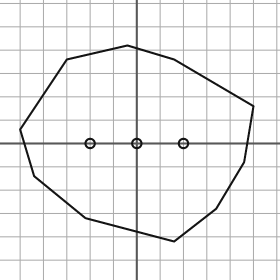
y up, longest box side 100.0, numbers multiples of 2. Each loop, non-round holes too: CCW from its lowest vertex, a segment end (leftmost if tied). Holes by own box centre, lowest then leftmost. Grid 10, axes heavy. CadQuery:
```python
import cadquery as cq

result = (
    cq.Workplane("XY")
    .moveTo(16.0, -42.0)
    .lineTo(34.0, -28.0)
    .lineTo(46.0, -8.0)
    .lineTo(50.0, 16.0)
    .lineTo(16.0, 36.0)
    .lineTo(-4.0, 42.0)
    .lineTo(-30.0, 36.0)
    .lineTo(-50.0, 6.0)
    .lineTo(-44.0, -14.0)
    .lineTo(-22.0, -32.0)
    .close()
    .moveTo(-20.0, 0.0)
    .circle(2.0)
    .moveTo(0.0, 0.0)
    .circle(2.0)
    .moveTo(20.0, 0.0)
    .circle(2.0)
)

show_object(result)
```